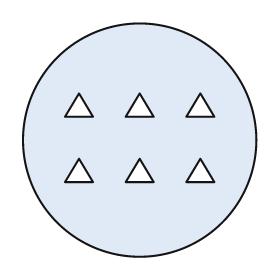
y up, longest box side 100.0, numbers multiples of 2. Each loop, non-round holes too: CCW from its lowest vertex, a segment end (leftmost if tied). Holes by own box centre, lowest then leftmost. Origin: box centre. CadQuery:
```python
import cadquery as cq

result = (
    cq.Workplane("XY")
    .moveTo(0.0, 0.0)
    .circle(50.0)
    .moveTo(-32.0, -18.0)
    .lineTo(-20.0, -18.0)
    .lineTo(-26.0, -8.0)
    .close()
    .moveTo(-6.0, -18.0)
    .lineTo(6.0, -18.0)
    .lineTo(0.0, -8.0)
    .close()
    .moveTo(20.0, -18.0)
    .lineTo(32.0, -18.0)
    .lineTo(26.0, -8.0)
    .close()
    .moveTo(-32.0, 10.0)
    .lineTo(-20.0, 10.0)
    .lineTo(-26.0, 20.0)
    .close()
    .moveTo(-6.0, 10.0)
    .lineTo(6.0, 10.0)
    .lineTo(0.0, 20.0)
    .close()
    .moveTo(20.0, 10.0)
    .lineTo(32.0, 10.0)
    .lineTo(26.0, 20.0)
    .close()
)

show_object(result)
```